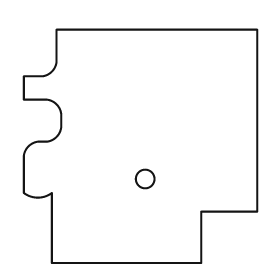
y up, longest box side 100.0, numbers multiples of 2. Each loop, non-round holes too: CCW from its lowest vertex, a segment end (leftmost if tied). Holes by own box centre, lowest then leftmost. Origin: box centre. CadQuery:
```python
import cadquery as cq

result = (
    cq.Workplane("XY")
    .moveTo(-38.0, -50.0)
    .lineTo(26.0, -50.0)
    .lineTo(26.0, -28.0)
    .lineTo(50.0, -28.0)
    .lineTo(50.0, 50.0)
    .lineTo(-36.0, 50.0)
    .lineTo(-36.0, 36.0)
    .threePointArc((-38.0, 32.0), (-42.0, 30.0))
    .lineTo(-50.0, 30.0)
    .lineTo(-50.0, 20.0)
    .lineTo(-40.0, 20.0)
    .threePointArc((-36.0, 18.0), (-34.0, 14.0))
    .lineTo(-34.0, 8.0)
    .threePointArc((-36.0, 4.0), (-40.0, 2.0))
    .lineTo(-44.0, 2.0)
    .threePointArc((-48.0, 0.0), (-50.0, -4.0))
    .lineTo(-50.0, -20.0)
    .threePointArc((-44.0, -22.0), (-38.0, -20.0))
    .close()
    .moveTo(2.0, -14.0)
    .circle(4.0)
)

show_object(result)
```